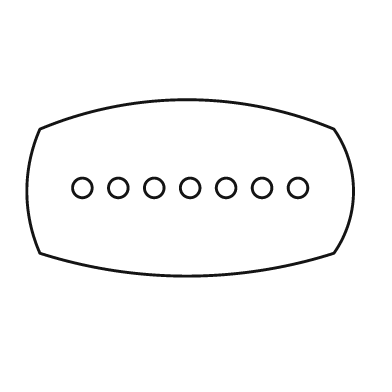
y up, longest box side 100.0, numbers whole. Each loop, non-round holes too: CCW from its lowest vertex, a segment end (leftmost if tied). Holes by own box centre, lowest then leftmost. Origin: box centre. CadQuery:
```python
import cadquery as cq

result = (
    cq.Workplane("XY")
    .moveTo(-46.0, -20.0)
    .threePointArc((-1.0, -27.0), (44.0, -20.0))
    .threePointArc((50.0, -1.0), (44.0, 18.0))
    .threePointArc((-1.0, 27.0), (-46.0, 18.0))
    .threePointArc((-50.0, -1.0), (-46.0, -20.0))
    .close()
    .moveTo(-33.0, 0.0)
    .circle(3.0)
    .moveTo(-22.0, 0.0)
    .circle(3.0)
    .moveTo(-11.0, 0.0)
    .circle(3.0)
    .moveTo(0.0, 0.0)
    .circle(3.0)
    .moveTo(11.0, 0.0)
    .circle(3.0)
    .moveTo(22.0, 0.0)
    .circle(3.0)
    .moveTo(33.0, 0.0)
    .circle(3.0)
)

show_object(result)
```